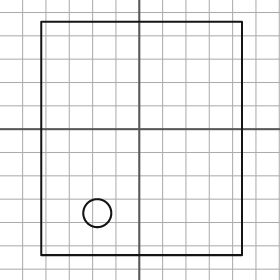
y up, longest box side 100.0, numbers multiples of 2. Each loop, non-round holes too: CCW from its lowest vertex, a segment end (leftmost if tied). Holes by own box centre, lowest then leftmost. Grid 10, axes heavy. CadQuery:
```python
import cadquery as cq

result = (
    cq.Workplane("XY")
    .moveTo(-42.0, -54.0)
    .lineTo(44.0, -54.0)
    .lineTo(44.0, 46.0)
    .lineTo(-42.0, 46.0)
    .close()
    .moveTo(-18.0, -36.0)
    .circle(6.0)
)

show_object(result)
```